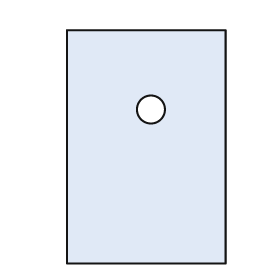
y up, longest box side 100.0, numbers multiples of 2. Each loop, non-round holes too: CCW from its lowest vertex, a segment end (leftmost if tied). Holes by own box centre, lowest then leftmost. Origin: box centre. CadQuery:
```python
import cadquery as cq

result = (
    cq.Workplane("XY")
    .moveTo(-34.0, -50.0)
    .lineTo(34.0, -50.0)
    .lineTo(34.0, 50.0)
    .lineTo(-34.0, 50.0)
    .close()
    .moveTo(2.0, 16.0)
    .circle(6.0)
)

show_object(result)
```